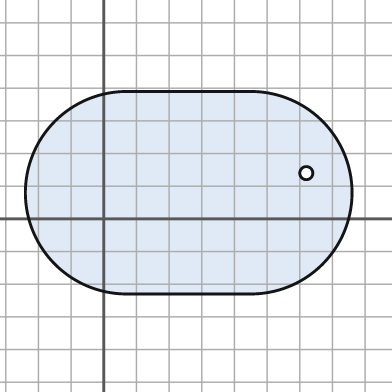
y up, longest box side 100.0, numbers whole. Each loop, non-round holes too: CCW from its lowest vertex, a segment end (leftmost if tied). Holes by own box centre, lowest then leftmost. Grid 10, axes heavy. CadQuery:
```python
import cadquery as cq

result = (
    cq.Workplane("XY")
    .moveTo(7.0, -23.0)
    .lineTo(45.0, -23.0)
    .threePointArc((76.0, 8.0), (45.0, 39.0))
    .lineTo(7.0, 39.0)
    .threePointArc((-24.0, 8.0), (7.0, -23.0))
    .close()
    .moveTo(62.0, 14.0)
    .circle(2.0)
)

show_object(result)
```